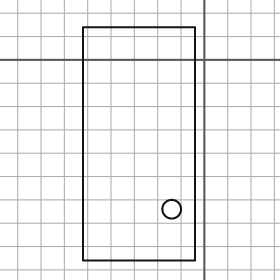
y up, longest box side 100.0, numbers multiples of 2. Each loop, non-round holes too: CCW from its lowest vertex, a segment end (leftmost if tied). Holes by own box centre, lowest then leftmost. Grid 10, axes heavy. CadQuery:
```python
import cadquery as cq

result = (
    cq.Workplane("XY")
    .moveTo(-52.0, -86.0)
    .lineTo(-4.0, -86.0)
    .lineTo(-4.0, 14.0)
    .lineTo(-52.0, 14.0)
    .close()
    .moveTo(-14.0, -64.0)
    .circle(4.0)
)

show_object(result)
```